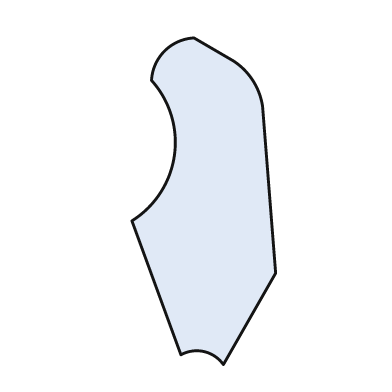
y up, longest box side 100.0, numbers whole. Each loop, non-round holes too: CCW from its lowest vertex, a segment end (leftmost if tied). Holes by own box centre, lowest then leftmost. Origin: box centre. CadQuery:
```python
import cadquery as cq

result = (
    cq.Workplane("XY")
    .moveTo(6.0, -50.0)
    .lineTo(22.0, -22.0)
    .lineTo(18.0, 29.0)
    .threePointArc((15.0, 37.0), (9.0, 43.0))
    .lineTo(-3.0, 50.0)
    .threePointArc((-12.0, 46.0), (-16.0, 37.0))
    .threePointArc((-9.0, 14.0), (-22.0, -6.0))
    .lineTo(-7.0, -47.0)
    .threePointArc((0.0, -46.0), (6.0, -50.0))
    .close()
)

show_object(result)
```